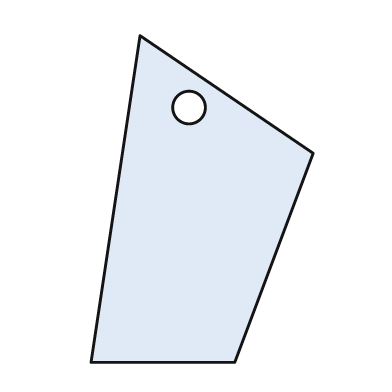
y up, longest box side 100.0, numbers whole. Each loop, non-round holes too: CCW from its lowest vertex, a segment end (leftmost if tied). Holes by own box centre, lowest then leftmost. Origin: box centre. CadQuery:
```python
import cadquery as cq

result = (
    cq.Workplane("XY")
    .moveTo(-34.0, -50.0)
    .lineTo(10.0, -50.0)
    .lineTo(34.0, 14.0)
    .lineTo(-19.0, 50.0)
    .close()
    .moveTo(-4.0, 28.0)
    .circle(5.0)
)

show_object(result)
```